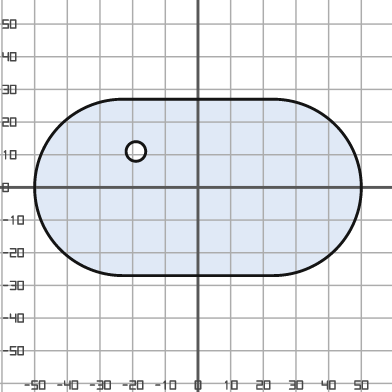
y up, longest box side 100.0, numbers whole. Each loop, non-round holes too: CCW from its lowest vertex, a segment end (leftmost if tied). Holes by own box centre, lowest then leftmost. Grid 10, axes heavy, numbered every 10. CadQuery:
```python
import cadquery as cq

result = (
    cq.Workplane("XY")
    .moveTo(-23.0, -27.0)
    .lineTo(23.0, -27.0)
    .threePointArc((50.0, 0.0), (23.0, 27.0))
    .lineTo(-23.0, 27.0)
    .threePointArc((-50.0, 0.0), (-23.0, -27.0))
    .close()
    .moveTo(-19.0, 11.0)
    .circle(3.0)
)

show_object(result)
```